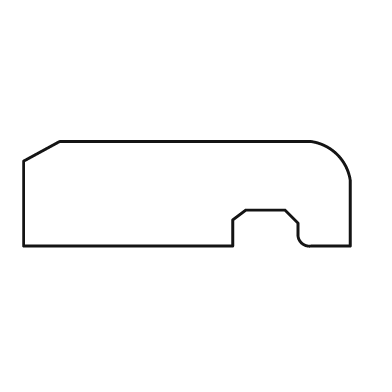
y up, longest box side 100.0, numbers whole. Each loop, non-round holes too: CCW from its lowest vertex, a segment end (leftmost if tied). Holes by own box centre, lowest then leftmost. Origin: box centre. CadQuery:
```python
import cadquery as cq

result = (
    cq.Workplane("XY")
    .moveTo(-50.0, -16.0)
    .lineTo(14.0, -16.0)
    .lineTo(14.0, -8.0)
    .lineTo(18.0, -5.0)
    .lineTo(30.0, -5.0)
    .lineTo(34.0, -9.0)
    .lineTo(34.0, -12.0)
    .threePointArc((35.0, -15.0), (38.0, -16.0))
    .lineTo(50.0, -16.0)
    .lineTo(50.0, 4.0)
    .threePointArc((46.0, 12.0), (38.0, 16.0))
    .lineTo(-39.0, 16.0)
    .lineTo(-50.0, 10.0)
    .close()
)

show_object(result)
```